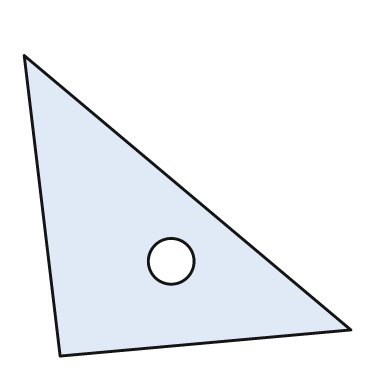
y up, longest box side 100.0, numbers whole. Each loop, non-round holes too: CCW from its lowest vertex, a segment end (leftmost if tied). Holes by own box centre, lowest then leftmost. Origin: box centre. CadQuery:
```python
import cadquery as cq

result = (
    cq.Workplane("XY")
    .moveTo(-39.0, -46.0)
    .lineTo(50.0, -38.0)
    .lineTo(-50.0, 46.0)
    .close()
    .moveTo(-5.0, -17.0)
    .circle(7.0)
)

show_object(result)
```